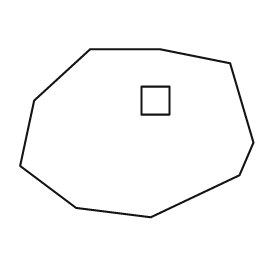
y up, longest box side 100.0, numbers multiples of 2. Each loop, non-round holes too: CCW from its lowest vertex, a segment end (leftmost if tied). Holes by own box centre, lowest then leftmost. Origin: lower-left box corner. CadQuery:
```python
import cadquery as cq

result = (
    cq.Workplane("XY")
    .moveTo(56.0, 0.0)
    .lineTo(94.0, 18.0)
    .lineTo(100.0, 32.0)
    .lineTo(90.0, 66.0)
    .lineTo(60.0, 72.0)
    .lineTo(30.0, 72.0)
    .lineTo(6.0, 50.0)
    .lineTo(0.0, 22.0)
    .lineTo(24.0, 4.0)
    .close()
    .moveTo(52.0, 44.0)
    .lineTo(64.0, 44.0)
    .lineTo(64.0, 56.0)
    .lineTo(52.0, 56.0)
    .close()
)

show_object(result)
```